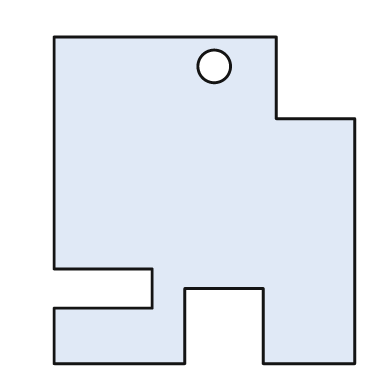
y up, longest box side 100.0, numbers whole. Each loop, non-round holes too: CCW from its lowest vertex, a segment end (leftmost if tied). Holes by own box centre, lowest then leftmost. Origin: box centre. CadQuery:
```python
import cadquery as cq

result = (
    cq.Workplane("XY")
    .moveTo(-46.0, -50.0)
    .lineTo(-6.0, -50.0)
    .lineTo(-6.0, -27.0)
    .lineTo(18.0, -27.0)
    .lineTo(18.0, -50.0)
    .lineTo(46.0, -50.0)
    .lineTo(46.0, 25.0)
    .lineTo(22.0, 25.0)
    .lineTo(22.0, 50.0)
    .lineTo(-46.0, 50.0)
    .lineTo(-46.0, -21.0)
    .lineTo(-16.0, -21.0)
    .lineTo(-16.0, -33.0)
    .lineTo(-46.0, -33.0)
    .close()
    .moveTo(3.0, 41.0)
    .circle(5.0)
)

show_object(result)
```